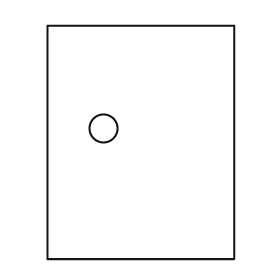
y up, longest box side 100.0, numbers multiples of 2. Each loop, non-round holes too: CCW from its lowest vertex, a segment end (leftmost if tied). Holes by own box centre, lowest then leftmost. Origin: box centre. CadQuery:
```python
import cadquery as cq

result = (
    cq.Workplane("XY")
    .moveTo(-40.0, -50.0)
    .lineTo(40.0, -50.0)
    .lineTo(40.0, 50.0)
    .lineTo(-40.0, 50.0)
    .close()
    .moveTo(-16.0, 6.0)
    .circle(6.0)
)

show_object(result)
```